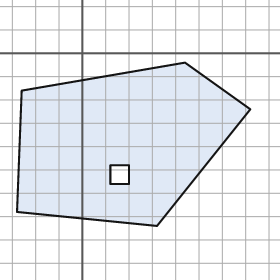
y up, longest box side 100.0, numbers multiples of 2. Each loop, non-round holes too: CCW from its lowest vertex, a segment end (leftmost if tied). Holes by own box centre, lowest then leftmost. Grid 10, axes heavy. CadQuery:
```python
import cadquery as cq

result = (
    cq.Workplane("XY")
    .moveTo(32.0, -74.0)
    .lineTo(72.0, -24.0)
    .lineTo(44.0, -4.0)
    .lineTo(-26.0, -16.0)
    .lineTo(-28.0, -68.0)
    .close()
    .moveTo(12.0, -56.0)
    .lineTo(20.0, -56.0)
    .lineTo(20.0, -48.0)
    .lineTo(12.0, -48.0)
    .close()
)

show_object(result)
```